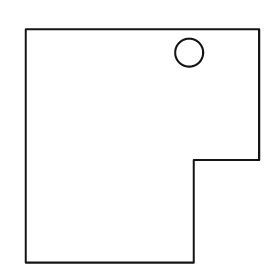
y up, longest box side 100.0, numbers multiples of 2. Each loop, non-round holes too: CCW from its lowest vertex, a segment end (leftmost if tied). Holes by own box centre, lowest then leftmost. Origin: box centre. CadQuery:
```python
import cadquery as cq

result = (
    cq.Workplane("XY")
    .moveTo(-50.0, -50.0)
    .lineTo(22.0, -50.0)
    .lineTo(22.0, -6.0)
    .lineTo(50.0, -6.0)
    .lineTo(50.0, 50.0)
    .lineTo(-50.0, 50.0)
    .close()
    .moveTo(20.0, 40.0)
    .circle(6.0)
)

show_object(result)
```